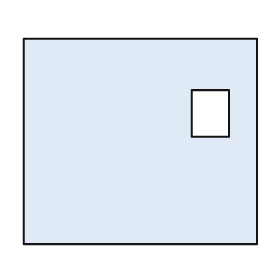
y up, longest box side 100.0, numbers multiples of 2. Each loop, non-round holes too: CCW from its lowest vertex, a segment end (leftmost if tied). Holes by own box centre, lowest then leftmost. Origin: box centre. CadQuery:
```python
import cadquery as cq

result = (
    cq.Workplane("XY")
    .moveTo(-50.0, -44.0)
    .lineTo(50.0, -44.0)
    .lineTo(50.0, 44.0)
    .lineTo(-50.0, 44.0)
    .close()
    .moveTo(22.0, 2.0)
    .lineTo(38.0, 2.0)
    .lineTo(38.0, 22.0)
    .lineTo(22.0, 22.0)
    .close()
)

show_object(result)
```